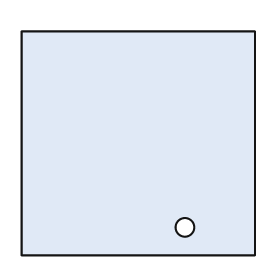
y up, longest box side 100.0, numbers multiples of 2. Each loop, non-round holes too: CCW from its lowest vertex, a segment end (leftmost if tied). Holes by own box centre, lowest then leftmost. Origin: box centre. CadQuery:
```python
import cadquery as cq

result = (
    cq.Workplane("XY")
    .moveTo(-50.0, -48.0)
    .lineTo(50.0, -48.0)
    .lineTo(50.0, 48.0)
    .lineTo(-50.0, 48.0)
    .close()
    .moveTo(20.0, -36.0)
    .circle(4.0)
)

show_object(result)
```